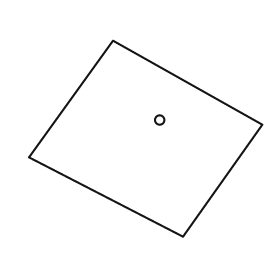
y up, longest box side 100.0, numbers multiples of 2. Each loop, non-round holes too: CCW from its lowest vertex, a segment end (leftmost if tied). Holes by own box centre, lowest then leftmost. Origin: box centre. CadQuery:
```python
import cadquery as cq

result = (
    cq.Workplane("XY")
    .moveTo(16.0, -42.0)
    .lineTo(50.0, 6.0)
    .lineTo(-14.0, 42.0)
    .lineTo(-50.0, -8.0)
    .close()
    .moveTo(6.0, 8.0)
    .circle(2.0)
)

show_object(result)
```